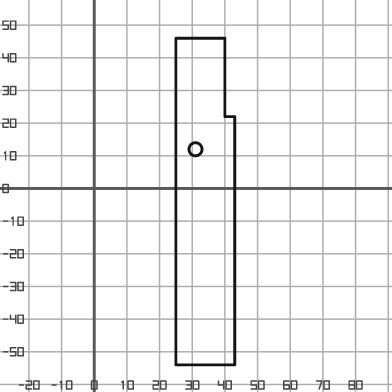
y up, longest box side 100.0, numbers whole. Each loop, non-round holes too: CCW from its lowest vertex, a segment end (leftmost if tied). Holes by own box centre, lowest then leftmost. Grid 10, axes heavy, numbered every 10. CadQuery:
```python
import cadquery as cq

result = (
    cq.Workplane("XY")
    .moveTo(25.0, -54.0)
    .lineTo(43.0, -54.0)
    .lineTo(43.0, 22.0)
    .lineTo(40.0, 22.0)
    .lineTo(40.0, 46.0)
    .lineTo(25.0, 46.0)
    .close()
    .moveTo(31.0, 12.0)
    .circle(2.0)
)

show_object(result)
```